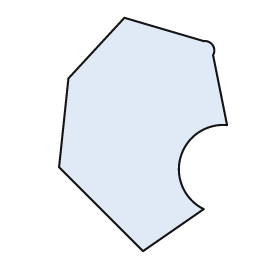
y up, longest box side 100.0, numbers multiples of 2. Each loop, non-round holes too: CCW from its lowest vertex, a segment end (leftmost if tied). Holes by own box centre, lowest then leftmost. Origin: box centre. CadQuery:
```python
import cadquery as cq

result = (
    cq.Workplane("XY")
    .moveTo(0.0, -50.0)
    .lineTo(26.0, -32.0)
    .threePointArc((16.0, -10.0), (36.0, 4.0))
    .lineTo(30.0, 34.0)
    .threePointArc((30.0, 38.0), (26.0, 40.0))
    .lineTo(-8.0, 50.0)
    .lineTo(-32.0, 24.0)
    .lineTo(-36.0, -14.0)
    .close()
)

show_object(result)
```